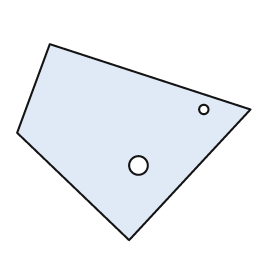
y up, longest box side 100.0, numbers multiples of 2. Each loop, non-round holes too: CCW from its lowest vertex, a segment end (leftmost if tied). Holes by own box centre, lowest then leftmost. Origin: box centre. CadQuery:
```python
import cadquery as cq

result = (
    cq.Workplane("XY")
    .moveTo(-2.0, -42.0)
    .lineTo(50.0, 14.0)
    .lineTo(-36.0, 42.0)
    .lineTo(-50.0, 4.0)
    .close()
    .moveTo(2.0, -10.0)
    .circle(4.0)
    .moveTo(30.0, 14.0)
    .circle(2.0)
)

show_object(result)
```